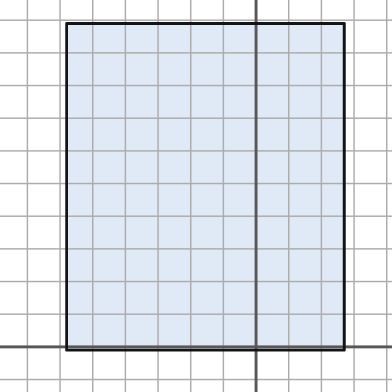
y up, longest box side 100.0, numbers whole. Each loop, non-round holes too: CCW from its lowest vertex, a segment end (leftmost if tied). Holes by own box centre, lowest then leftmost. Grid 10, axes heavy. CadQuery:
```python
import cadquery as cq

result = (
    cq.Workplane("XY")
    .moveTo(-58.0, -1.0)
    .lineTo(27.0, -1.0)
    .lineTo(27.0, 99.0)
    .lineTo(-58.0, 99.0)
    .close()
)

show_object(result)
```